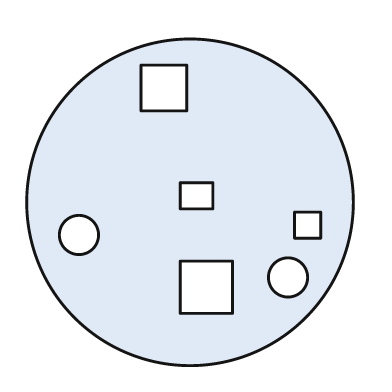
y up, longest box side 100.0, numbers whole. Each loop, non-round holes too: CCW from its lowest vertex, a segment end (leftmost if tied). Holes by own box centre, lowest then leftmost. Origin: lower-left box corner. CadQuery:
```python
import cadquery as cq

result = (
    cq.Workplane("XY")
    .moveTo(50.0, 50.0)
    .circle(50.0)
    .moveTo(47.0, 16.0)
    .lineTo(63.0, 16.0)
    .lineTo(63.0, 32.0)
    .lineTo(47.0, 32.0)
    .close()
    .moveTo(80.0, 27.0)
    .circle(6.0)
    .moveTo(16.0, 40.0)
    .circle(6.0)
    .moveTo(82.0, 39.0)
    .lineTo(90.0, 39.0)
    .lineTo(90.0, 47.0)
    .lineTo(82.0, 47.0)
    .close()
    .moveTo(47.0, 48.0)
    .lineTo(57.0, 48.0)
    .lineTo(57.0, 56.0)
    .lineTo(47.0, 56.0)
    .close()
    .moveTo(35.0, 78.0)
    .lineTo(49.0, 78.0)
    .lineTo(49.0, 92.0)
    .lineTo(35.0, 92.0)
    .close()
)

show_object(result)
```